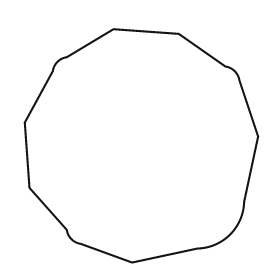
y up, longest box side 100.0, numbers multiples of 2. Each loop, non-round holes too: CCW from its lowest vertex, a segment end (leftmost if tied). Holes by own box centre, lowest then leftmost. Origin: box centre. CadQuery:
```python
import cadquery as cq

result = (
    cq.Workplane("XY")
    .moveTo(-4.0, -50.0)
    .lineTo(24.0, -44.0)
    .threePointArc((38.0, -38.0), (44.0, -24.0))
    .lineTo(50.0, 4.0)
    .lineTo(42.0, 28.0)
    .threePointArc((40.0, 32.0), (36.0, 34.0))
    .lineTo(16.0, 48.0)
    .lineTo(-12.0, 50.0)
    .lineTo(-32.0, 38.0)
    .threePointArc((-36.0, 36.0), (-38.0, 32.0))
    .lineTo(-50.0, 10.0)
    .lineTo(-48.0, -18.0)
    .lineTo(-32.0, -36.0)
    .threePointArc((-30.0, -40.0), (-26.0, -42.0))
    .close()
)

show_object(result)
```